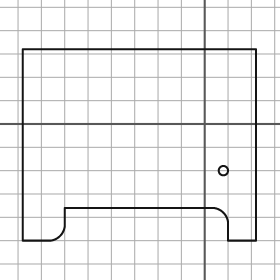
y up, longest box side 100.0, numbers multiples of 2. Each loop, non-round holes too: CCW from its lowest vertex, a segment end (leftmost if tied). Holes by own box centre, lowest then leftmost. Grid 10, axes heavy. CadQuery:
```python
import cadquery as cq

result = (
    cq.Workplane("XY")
    .moveTo(-78.0, -50.0)
    .lineTo(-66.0, -50.0)
    .threePointArc((-62.0, -48.0), (-60.0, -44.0))
    .lineTo(-60.0, -36.0)
    .lineTo(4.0, -36.0)
    .threePointArc((8.0, -38.0), (10.0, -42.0))
    .lineTo(10.0, -50.0)
    .lineTo(22.0, -50.0)
    .lineTo(22.0, 32.0)
    .lineTo(-78.0, 32.0)
    .close()
    .moveTo(8.0, -20.0)
    .circle(2.0)
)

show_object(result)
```